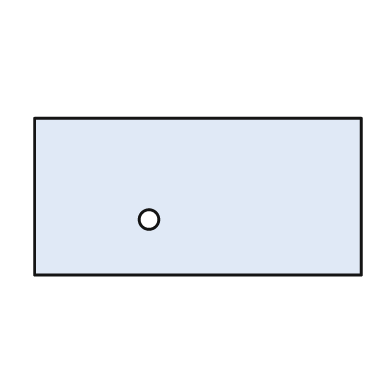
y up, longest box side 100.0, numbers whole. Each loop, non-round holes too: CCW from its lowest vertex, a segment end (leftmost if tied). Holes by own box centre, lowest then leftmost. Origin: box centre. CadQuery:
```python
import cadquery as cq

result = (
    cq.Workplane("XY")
    .moveTo(-50.0, -24.0)
    .lineTo(50.0, -24.0)
    .lineTo(50.0, 24.0)
    .lineTo(-50.0, 24.0)
    .close()
    .moveTo(-15.0, -7.0)
    .circle(3.0)
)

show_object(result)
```